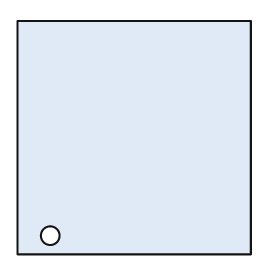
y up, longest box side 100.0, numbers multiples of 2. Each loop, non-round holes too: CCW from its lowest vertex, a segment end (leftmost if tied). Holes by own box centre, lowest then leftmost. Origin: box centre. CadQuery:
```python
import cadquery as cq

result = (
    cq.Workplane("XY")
    .moveTo(-50.0, -50.0)
    .lineTo(50.0, -50.0)
    .lineTo(50.0, 50.0)
    .lineTo(-50.0, 50.0)
    .close()
    .moveTo(-36.0, -42.0)
    .circle(4.0)
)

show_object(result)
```